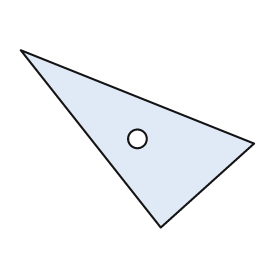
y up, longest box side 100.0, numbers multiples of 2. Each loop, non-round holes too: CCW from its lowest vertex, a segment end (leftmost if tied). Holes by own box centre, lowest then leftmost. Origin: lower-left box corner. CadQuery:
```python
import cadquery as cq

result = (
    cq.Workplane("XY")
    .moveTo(60.0, 0.0)
    .lineTo(100.0, 36.0)
    .lineTo(0.0, 76.0)
    .close()
    .moveTo(50.0, 38.0)
    .circle(4.0)
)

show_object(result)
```